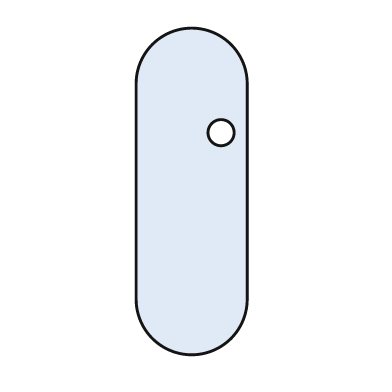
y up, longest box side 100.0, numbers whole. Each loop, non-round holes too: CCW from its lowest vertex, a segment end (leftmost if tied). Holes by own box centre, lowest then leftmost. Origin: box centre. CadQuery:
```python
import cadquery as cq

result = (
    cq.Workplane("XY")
    .moveTo(-17.0, -33.0)
    .threePointArc((0.0, -50.0), (17.0, -33.0))
    .lineTo(17.0, 33.0)
    .threePointArc((0.0, 50.0), (-17.0, 33.0))
    .close()
    .moveTo(9.0, 18.0)
    .circle(4.0)
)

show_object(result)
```